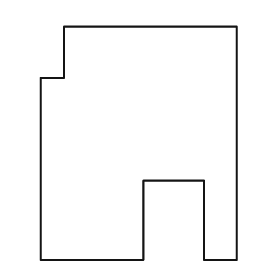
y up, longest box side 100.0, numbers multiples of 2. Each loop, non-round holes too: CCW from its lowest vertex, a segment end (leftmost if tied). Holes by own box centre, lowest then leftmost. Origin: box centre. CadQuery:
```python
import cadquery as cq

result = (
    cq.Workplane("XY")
    .moveTo(-42.0, -50.0)
    .lineTo(2.0, -50.0)
    .lineTo(2.0, -16.0)
    .lineTo(28.0, -16.0)
    .lineTo(28.0, -50.0)
    .lineTo(42.0, -50.0)
    .lineTo(42.0, 50.0)
    .lineTo(-32.0, 50.0)
    .lineTo(-32.0, 28.0)
    .lineTo(-42.0, 28.0)
    .close()
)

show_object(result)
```